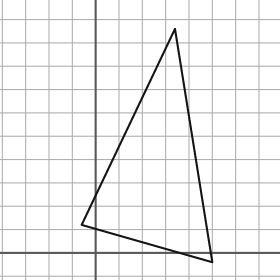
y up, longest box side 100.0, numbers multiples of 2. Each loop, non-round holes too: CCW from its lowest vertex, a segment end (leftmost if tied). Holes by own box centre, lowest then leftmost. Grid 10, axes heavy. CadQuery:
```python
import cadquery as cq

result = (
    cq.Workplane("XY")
    .moveTo(50.0, -4.0)
    .lineTo(34.0, 96.0)
    .lineTo(-6.0, 12.0)
    .close()
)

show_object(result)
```